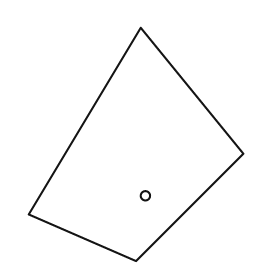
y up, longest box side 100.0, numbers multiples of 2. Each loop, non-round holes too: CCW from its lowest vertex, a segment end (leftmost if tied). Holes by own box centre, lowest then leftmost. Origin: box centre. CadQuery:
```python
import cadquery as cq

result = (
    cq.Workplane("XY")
    .moveTo(0.0, -50.0)
    .lineTo(46.0, -4.0)
    .lineTo(2.0, 50.0)
    .lineTo(-46.0, -30.0)
    .close()
    .moveTo(4.0, -22.0)
    .circle(2.0)
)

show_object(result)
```